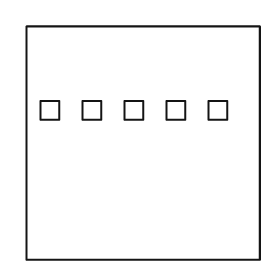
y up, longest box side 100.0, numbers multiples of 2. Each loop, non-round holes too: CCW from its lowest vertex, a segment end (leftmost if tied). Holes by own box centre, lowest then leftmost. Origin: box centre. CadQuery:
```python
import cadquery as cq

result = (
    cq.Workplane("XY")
    .moveTo(-50.0, -50.0)
    .lineTo(50.0, -50.0)
    .lineTo(50.0, 50.0)
    .lineTo(-50.0, 50.0)
    .close()
    .moveTo(-44.0, 10.0)
    .lineTo(-36.0, 10.0)
    .lineTo(-36.0, 18.0)
    .lineTo(-44.0, 18.0)
    .close()
    .moveTo(-26.0, 10.0)
    .lineTo(-18.0, 10.0)
    .lineTo(-18.0, 18.0)
    .lineTo(-26.0, 18.0)
    .close()
    .moveTo(-8.0, 10.0)
    .lineTo(0.0, 10.0)
    .lineTo(0.0, 18.0)
    .lineTo(-8.0, 18.0)
    .close()
    .moveTo(10.0, 10.0)
    .lineTo(18.0, 10.0)
    .lineTo(18.0, 18.0)
    .lineTo(10.0, 18.0)
    .close()
    .moveTo(28.0, 10.0)
    .lineTo(36.0, 10.0)
    .lineTo(36.0, 18.0)
    .lineTo(28.0, 18.0)
    .close()
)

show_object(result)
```